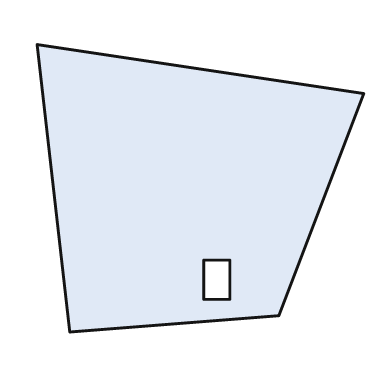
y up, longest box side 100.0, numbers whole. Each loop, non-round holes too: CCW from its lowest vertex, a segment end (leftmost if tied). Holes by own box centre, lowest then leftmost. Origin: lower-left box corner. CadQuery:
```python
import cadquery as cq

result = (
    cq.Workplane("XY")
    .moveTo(10.0, 0.0)
    .lineTo(74.0, 5.0)
    .lineTo(100.0, 73.0)
    .lineTo(0.0, 88.0)
    .close()
    .moveTo(51.0, 10.0)
    .lineTo(59.0, 10.0)
    .lineTo(59.0, 22.0)
    .lineTo(51.0, 22.0)
    .close()
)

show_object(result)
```